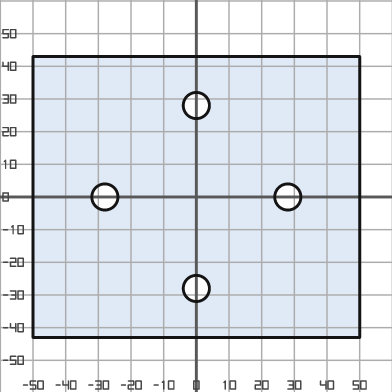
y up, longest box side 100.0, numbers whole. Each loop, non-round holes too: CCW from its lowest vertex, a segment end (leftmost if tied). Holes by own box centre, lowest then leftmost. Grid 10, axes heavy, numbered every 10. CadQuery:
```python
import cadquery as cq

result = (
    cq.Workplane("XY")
    .moveTo(-50.0, -43.0)
    .lineTo(50.0, -43.0)
    .lineTo(50.0, 43.0)
    .lineTo(-50.0, 43.0)
    .close()
    .moveTo(0.0, -28.0)
    .circle(4.0)
    .moveTo(-28.0, 0.0)
    .circle(4.0)
    .moveTo(28.0, 0.0)
    .circle(4.0)
    .moveTo(0.0, 28.0)
    .circle(4.0)
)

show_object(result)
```